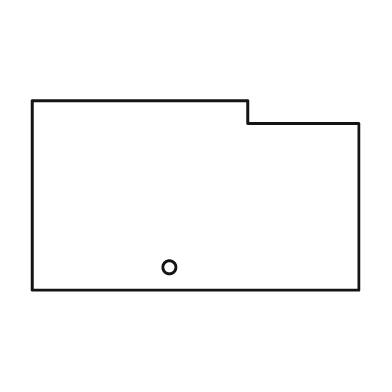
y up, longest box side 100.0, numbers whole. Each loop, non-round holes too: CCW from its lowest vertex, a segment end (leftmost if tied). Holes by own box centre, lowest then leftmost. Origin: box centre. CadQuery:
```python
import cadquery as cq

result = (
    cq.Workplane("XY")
    .moveTo(-50.0, -29.0)
    .lineTo(50.0, -29.0)
    .lineTo(50.0, 22.0)
    .lineTo(16.0, 22.0)
    .lineTo(16.0, 29.0)
    .lineTo(-50.0, 29.0)
    .close()
    .moveTo(-8.0, -22.0)
    .circle(2.0)
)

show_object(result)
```